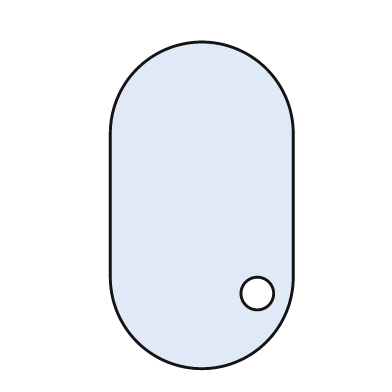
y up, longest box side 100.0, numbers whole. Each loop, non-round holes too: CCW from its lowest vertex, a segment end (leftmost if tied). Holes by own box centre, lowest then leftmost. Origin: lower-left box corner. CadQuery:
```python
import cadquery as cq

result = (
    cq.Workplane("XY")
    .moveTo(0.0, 28.0)
    .threePointArc((28.0, 0.0), (56.0, 28.0))
    .lineTo(56.0, 72.0)
    .threePointArc((28.0, 100.0), (0.0, 72.0))
    .close()
    .moveTo(45.0, 23.0)
    .circle(5.0)
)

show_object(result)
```